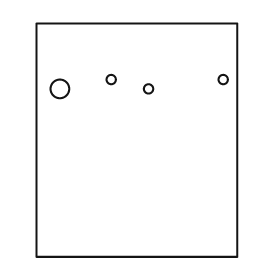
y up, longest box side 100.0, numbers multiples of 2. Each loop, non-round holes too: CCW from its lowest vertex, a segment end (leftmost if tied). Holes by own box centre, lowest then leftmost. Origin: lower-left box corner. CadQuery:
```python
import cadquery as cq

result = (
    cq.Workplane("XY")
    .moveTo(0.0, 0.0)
    .lineTo(86.0, 0.0)
    .lineTo(86.0, 100.0)
    .lineTo(0.0, 100.0)
    .close()
    .moveTo(10.0, 72.0)
    .circle(4.0)
    .moveTo(48.0, 72.0)
    .circle(2.0)
    .moveTo(32.0, 76.0)
    .circle(2.0)
    .moveTo(80.0, 76.0)
    .circle(2.0)
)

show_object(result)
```